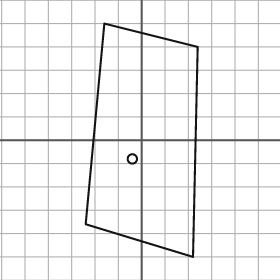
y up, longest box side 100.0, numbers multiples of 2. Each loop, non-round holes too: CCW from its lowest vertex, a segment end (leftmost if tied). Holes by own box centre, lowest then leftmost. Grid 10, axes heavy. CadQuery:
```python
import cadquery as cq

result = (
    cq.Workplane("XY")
    .moveTo(22.0, -50.0)
    .lineTo(24.0, 40.0)
    .lineTo(-16.0, 50.0)
    .lineTo(-24.0, -36.0)
    .close()
    .moveTo(-4.0, -8.0)
    .circle(2.0)
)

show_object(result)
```